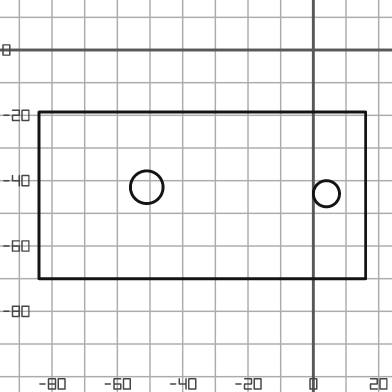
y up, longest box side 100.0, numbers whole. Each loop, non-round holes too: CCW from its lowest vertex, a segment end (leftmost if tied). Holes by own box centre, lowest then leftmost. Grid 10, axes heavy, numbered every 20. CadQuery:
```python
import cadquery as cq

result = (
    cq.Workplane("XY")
    .moveTo(-84.0, -70.0)
    .lineTo(16.0, -70.0)
    .lineTo(16.0, -19.0)
    .lineTo(-84.0, -19.0)
    .close()
    .moveTo(4.0, -44.0)
    .circle(4.0)
    .moveTo(-51.0, -42.0)
    .circle(5.0)
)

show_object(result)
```